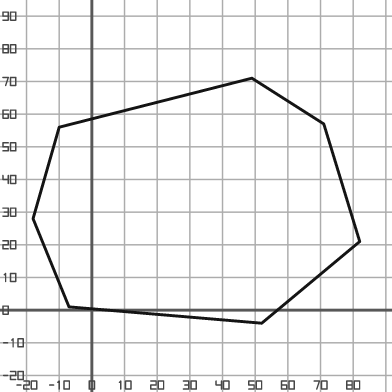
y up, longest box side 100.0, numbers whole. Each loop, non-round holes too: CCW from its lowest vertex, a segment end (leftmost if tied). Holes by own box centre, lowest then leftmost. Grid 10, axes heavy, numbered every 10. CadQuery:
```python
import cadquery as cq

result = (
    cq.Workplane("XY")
    .moveTo(52.0, -4.0)
    .lineTo(82.0, 21.0)
    .lineTo(71.0, 57.0)
    .lineTo(49.0, 71.0)
    .lineTo(-10.0, 56.0)
    .lineTo(-18.0, 28.0)
    .lineTo(-7.0, 1.0)
    .close()
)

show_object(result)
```